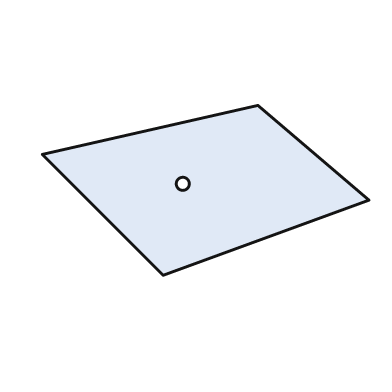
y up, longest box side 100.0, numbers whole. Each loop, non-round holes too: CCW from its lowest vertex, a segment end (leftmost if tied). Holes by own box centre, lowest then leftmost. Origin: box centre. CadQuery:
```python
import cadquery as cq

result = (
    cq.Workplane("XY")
    .moveTo(-13.0, -26.0)
    .lineTo(50.0, -3.0)
    .lineTo(16.0, 26.0)
    .lineTo(-50.0, 11.0)
    .close()
    .moveTo(-7.0, 2.0)
    .circle(2.0)
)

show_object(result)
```